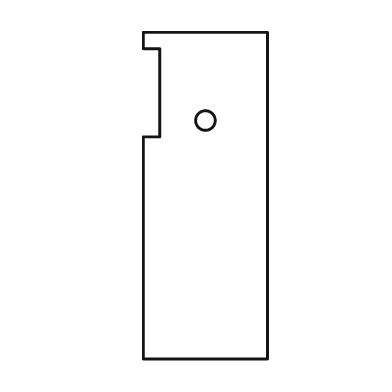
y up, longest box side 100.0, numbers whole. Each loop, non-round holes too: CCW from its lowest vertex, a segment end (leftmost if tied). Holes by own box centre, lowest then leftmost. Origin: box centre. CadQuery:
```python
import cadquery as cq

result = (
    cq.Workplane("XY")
    .moveTo(-19.0, -50.0)
    .lineTo(19.0, -50.0)
    .lineTo(19.0, 50.0)
    .lineTo(-19.0, 50.0)
    .lineTo(-19.0, 45.0)
    .lineTo(-14.0, 45.0)
    .lineTo(-14.0, 18.0)
    .lineTo(-19.0, 18.0)
    .close()
    .moveTo(0.0, 23.0)
    .circle(3.0)
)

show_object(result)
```